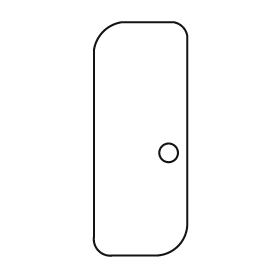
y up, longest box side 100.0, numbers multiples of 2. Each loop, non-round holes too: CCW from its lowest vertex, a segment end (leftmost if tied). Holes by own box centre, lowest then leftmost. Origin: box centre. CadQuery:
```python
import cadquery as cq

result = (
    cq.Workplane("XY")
    .moveTo(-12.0, -50.0)
    .lineTo(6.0, -50.0)
    .threePointArc((16.0, -46.0), (20.0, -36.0))
    .lineTo(20.0, 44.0)
    .threePointArc((18.0, 48.0), (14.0, 50.0))
    .lineTo(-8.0, 50.0)
    .threePointArc((-16.0, 46.0), (-20.0, 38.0))
    .lineTo(-20.0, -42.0)
    .threePointArc((-18.0, -48.0), (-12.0, -50.0))
    .close()
    .moveTo(12.0, -6.0)
    .circle(4.0)
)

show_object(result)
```